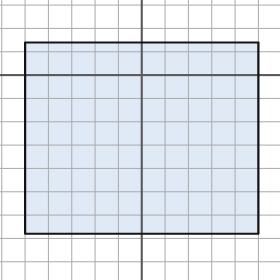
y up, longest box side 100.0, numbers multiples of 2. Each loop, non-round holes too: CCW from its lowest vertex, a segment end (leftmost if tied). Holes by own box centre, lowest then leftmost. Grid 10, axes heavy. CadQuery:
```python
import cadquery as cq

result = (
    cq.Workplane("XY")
    .moveTo(-50.0, -68.0)
    .lineTo(50.0, -68.0)
    .lineTo(50.0, 14.0)
    .lineTo(-50.0, 14.0)
    .close()
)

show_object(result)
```